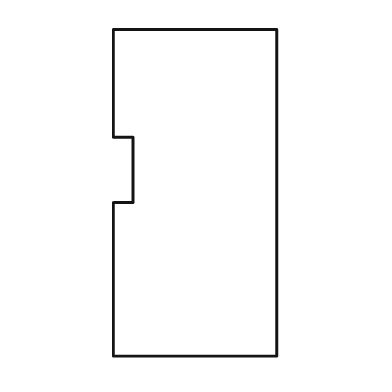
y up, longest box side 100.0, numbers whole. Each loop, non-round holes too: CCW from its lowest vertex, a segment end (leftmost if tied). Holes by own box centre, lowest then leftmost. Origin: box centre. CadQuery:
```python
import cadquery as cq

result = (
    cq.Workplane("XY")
    .moveTo(-25.0, -50.0)
    .lineTo(25.0, -50.0)
    .lineTo(25.0, 50.0)
    .lineTo(-25.0, 50.0)
    .lineTo(-25.0, 17.0)
    .lineTo(-19.0, 17.0)
    .lineTo(-19.0, -3.0)
    .lineTo(-25.0, -3.0)
    .close()
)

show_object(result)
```